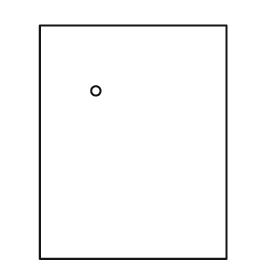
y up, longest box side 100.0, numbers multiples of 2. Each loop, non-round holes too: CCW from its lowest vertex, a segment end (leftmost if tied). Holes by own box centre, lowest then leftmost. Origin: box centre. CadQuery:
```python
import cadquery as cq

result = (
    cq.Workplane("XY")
    .moveTo(-40.0, -50.0)
    .lineTo(40.0, -50.0)
    .lineTo(40.0, 50.0)
    .lineTo(-40.0, 50.0)
    .close()
    .moveTo(-16.0, 22.0)
    .circle(2.0)
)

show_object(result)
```